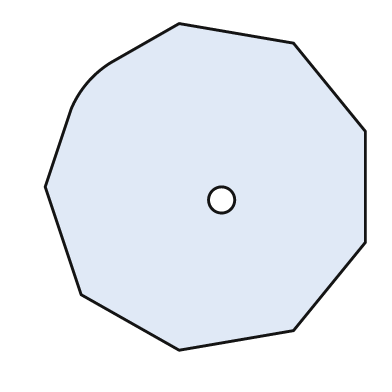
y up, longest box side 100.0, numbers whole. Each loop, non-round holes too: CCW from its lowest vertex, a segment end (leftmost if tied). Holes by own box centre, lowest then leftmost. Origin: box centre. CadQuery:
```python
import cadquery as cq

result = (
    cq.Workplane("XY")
    .moveTo(-8.0, -50.0)
    .lineTo(27.0, -44.0)
    .lineTo(49.0, -17.0)
    .lineTo(49.0, 17.0)
    .lineTo(27.0, 44.0)
    .lineTo(-8.0, 50.0)
    .lineTo(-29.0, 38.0)
    .threePointArc((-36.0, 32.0), (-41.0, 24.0))
    .lineTo(-49.0, 0.0)
    .lineTo(-38.0, -33.0)
    .close()
    .moveTo(5.0, -4.0)
    .circle(4.0)
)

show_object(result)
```